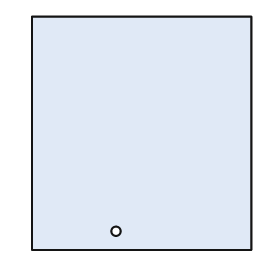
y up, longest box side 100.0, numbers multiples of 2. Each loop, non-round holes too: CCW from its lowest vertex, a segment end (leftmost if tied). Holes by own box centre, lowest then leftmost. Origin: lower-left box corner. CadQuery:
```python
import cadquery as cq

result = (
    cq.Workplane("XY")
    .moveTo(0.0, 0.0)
    .lineTo(94.0, 0.0)
    .lineTo(94.0, 100.0)
    .lineTo(0.0, 100.0)
    .close()
    .moveTo(36.0, 8.0)
    .circle(2.0)
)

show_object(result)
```